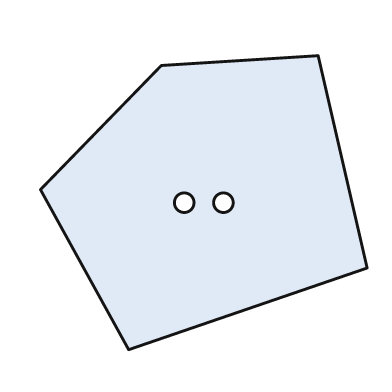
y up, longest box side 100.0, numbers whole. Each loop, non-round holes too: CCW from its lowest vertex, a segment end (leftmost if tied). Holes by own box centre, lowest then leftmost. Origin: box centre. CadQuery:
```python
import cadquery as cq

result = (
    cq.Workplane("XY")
    .moveTo(-23.0, -45.0)
    .lineTo(50.0, -20.0)
    .lineTo(35.0, 45.0)
    .lineTo(-13.0, 42.0)
    .lineTo(-50.0, 4.0)
    .close()
    .moveTo(-6.0, 0.0)
    .circle(3.0)
    .moveTo(6.0, 0.0)
    .circle(3.0)
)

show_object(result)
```